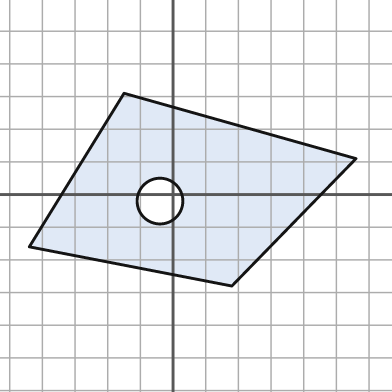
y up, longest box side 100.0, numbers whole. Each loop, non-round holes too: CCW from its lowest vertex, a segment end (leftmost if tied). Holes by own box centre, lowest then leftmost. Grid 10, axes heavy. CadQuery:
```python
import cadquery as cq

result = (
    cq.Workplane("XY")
    .moveTo(18.0, -28.0)
    .lineTo(56.0, 11.0)
    .lineTo(-15.0, 31.0)
    .lineTo(-44.0, -16.0)
    .close()
    .moveTo(-4.0, -2.0)
    .circle(7.0)
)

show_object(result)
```